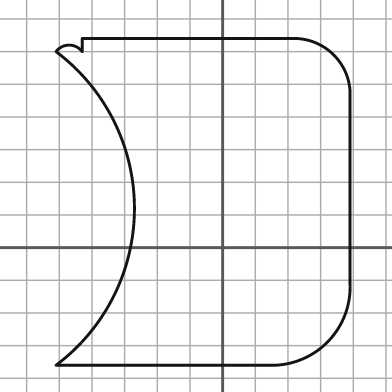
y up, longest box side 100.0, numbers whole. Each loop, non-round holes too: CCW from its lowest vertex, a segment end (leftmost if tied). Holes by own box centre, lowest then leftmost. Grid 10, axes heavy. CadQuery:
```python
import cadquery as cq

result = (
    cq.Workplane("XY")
    .moveTo(-51.0, -36.0)
    .lineTo(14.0, -36.0)
    .threePointArc((32.0, -29.0), (39.0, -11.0))
    .lineTo(39.0, 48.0)
    .threePointArc((34.0, 59.0), (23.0, 64.0))
    .lineTo(-43.0, 64.0)
    .lineTo(-43.0, 60.0)
    .threePointArc((-47.0, 62.0), (-51.0, 60.0))
    .threePointArc((-27.0, 12.0), (-51.0, -36.0))
    .close()
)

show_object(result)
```